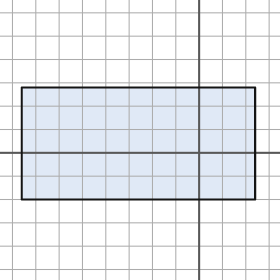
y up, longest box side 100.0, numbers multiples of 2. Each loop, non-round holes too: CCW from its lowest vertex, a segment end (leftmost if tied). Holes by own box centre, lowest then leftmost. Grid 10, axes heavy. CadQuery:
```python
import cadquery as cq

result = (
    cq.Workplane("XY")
    .moveTo(-76.0, -20.0)
    .lineTo(24.0, -20.0)
    .lineTo(24.0, 28.0)
    .lineTo(-76.0, 28.0)
    .close()
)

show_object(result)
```